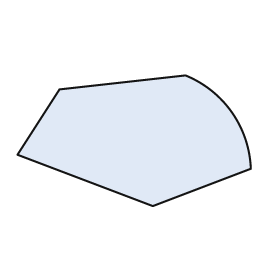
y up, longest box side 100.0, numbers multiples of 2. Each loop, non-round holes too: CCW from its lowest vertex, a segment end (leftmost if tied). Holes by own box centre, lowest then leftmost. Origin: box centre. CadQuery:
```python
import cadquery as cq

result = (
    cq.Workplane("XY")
    .moveTo(8.0, -28.0)
    .lineTo(50.0, -12.0)
    .threePointArc((42.0, 12.0), (22.0, 28.0))
    .lineTo(-32.0, 22.0)
    .lineTo(-50.0, -6.0)
    .close()
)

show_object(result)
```